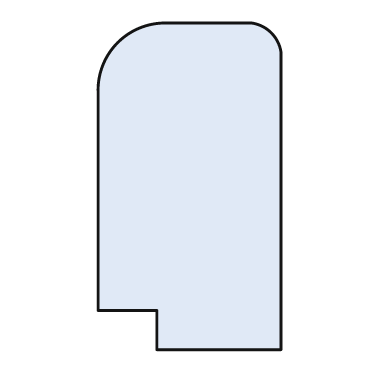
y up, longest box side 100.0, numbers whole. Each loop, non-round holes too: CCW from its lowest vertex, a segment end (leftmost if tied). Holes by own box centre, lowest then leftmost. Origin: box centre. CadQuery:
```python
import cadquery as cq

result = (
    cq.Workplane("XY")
    .moveTo(-10.0, -50.0)
    .lineTo(28.0, -50.0)
    .lineTo(28.0, 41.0)
    .threePointArc((25.0, 47.0), (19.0, 50.0))
    .lineTo(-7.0, 50.0)
    .threePointArc((-22.0, 44.0), (-28.0, 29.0))
    .lineTo(-28.0, -38.0)
    .lineTo(-10.0, -38.0)
    .close()
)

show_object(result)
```